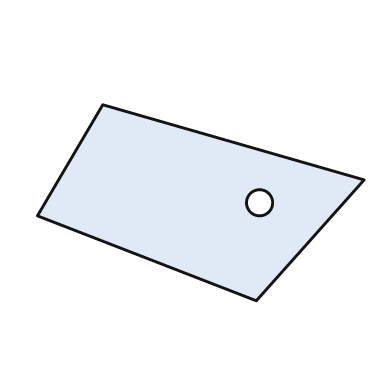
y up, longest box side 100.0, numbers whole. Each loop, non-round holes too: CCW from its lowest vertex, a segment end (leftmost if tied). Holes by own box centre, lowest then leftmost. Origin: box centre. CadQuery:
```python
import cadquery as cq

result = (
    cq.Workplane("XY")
    .moveTo(17.0, -30.0)
    .lineTo(50.0, 7.0)
    .lineTo(-30.0, 30.0)
    .lineTo(-50.0, -4.0)
    .close()
    .moveTo(18.0, 0.0)
    .circle(4.0)
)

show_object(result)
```